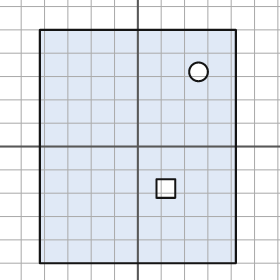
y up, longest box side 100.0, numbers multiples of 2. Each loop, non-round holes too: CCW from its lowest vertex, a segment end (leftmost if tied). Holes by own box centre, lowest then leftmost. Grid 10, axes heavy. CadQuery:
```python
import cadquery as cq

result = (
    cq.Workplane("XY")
    .moveTo(-42.0, -50.0)
    .lineTo(42.0, -50.0)
    .lineTo(42.0, 50.0)
    .lineTo(-42.0, 50.0)
    .close()
    .moveTo(8.0, -22.0)
    .lineTo(16.0, -22.0)
    .lineTo(16.0, -14.0)
    .lineTo(8.0, -14.0)
    .close()
    .moveTo(26.0, 32.0)
    .circle(4.0)
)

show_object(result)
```